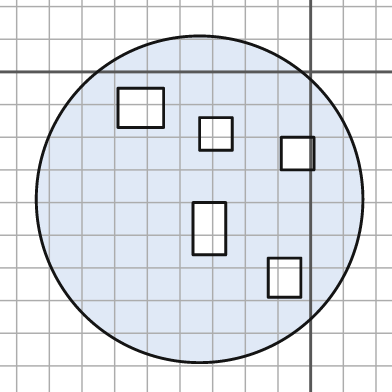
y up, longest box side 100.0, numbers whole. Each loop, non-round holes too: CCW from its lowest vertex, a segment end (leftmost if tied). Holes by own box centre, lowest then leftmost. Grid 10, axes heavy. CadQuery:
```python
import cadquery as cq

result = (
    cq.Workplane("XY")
    .moveTo(-34.0, -39.0)
    .circle(50.0)
    .moveTo(-13.0, -69.0)
    .lineTo(-3.0, -69.0)
    .lineTo(-3.0, -57.0)
    .lineTo(-13.0, -57.0)
    .close()
    .moveTo(-36.0, -56.0)
    .lineTo(-26.0, -56.0)
    .lineTo(-26.0, -40.0)
    .lineTo(-36.0, -40.0)
    .close()
    .moveTo(-9.0, -30.0)
    .lineTo(1.0, -30.0)
    .lineTo(1.0, -20.0)
    .lineTo(-9.0, -20.0)
    .close()
    .moveTo(-34.0, -24.0)
    .lineTo(-24.0, -24.0)
    .lineTo(-24.0, -14.0)
    .lineTo(-34.0, -14.0)
    .close()
    .moveTo(-59.0, -17.0)
    .lineTo(-45.0, -17.0)
    .lineTo(-45.0, -5.0)
    .lineTo(-59.0, -5.0)
    .close()
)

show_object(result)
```